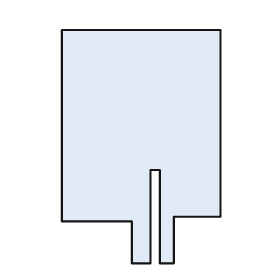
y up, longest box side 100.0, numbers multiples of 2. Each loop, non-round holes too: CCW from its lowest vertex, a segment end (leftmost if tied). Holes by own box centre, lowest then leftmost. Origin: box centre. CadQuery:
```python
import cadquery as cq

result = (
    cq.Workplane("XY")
    .moveTo(-4.0, -50.0)
    .lineTo(4.0, -50.0)
    .lineTo(4.0, -10.0)
    .lineTo(8.0, -10.0)
    .lineTo(8.0, -50.0)
    .lineTo(14.0, -50.0)
    .lineTo(14.0, -30.0)
    .lineTo(34.0, -30.0)
    .lineTo(34.0, 50.0)
    .lineTo(-34.0, 50.0)
    .lineTo(-34.0, -32.0)
    .lineTo(-4.0, -32.0)
    .close()
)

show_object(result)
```